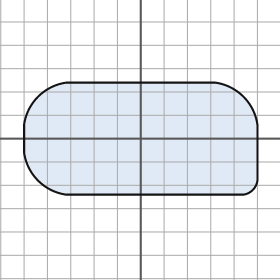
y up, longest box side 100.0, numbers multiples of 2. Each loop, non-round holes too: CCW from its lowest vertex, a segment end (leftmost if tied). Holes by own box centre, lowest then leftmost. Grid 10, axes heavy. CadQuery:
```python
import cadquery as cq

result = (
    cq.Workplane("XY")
    .moveTo(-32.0, -24.0)
    .lineTo(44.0, -24.0)
    .threePointArc((48.0, -22.0), (50.0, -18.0))
    .lineTo(50.0, 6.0)
    .threePointArc((44.0, 18.0), (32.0, 24.0))
    .lineTo(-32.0, 24.0)
    .threePointArc((-44.0, 18.0), (-50.0, 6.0))
    .lineTo(-50.0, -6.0)
    .threePointArc((-44.0, -18.0), (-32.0, -24.0))
    .close()
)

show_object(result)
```